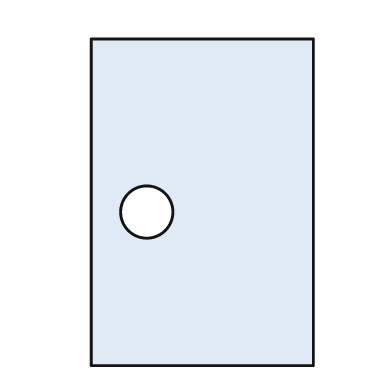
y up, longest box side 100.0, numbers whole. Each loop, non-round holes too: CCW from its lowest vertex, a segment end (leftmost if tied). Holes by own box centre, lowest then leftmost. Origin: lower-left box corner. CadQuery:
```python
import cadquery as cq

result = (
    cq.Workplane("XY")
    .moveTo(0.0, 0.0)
    .lineTo(68.0, 0.0)
    .lineTo(68.0, 100.0)
    .lineTo(0.0, 100.0)
    .close()
    .moveTo(17.0, 47.0)
    .circle(8.0)
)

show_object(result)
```